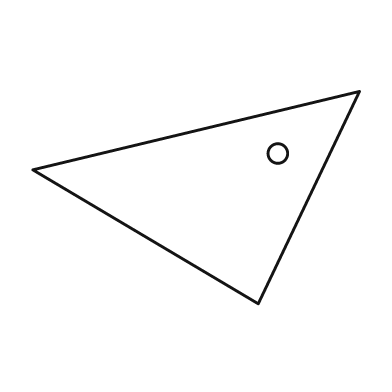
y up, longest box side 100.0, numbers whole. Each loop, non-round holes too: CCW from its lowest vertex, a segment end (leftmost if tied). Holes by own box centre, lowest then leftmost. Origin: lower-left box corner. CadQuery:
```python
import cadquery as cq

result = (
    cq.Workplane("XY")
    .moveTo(69.0, 0.0)
    .lineTo(100.0, 65.0)
    .lineTo(0.0, 41.0)
    .close()
    .moveTo(75.0, 46.0)
    .circle(3.0)
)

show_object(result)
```